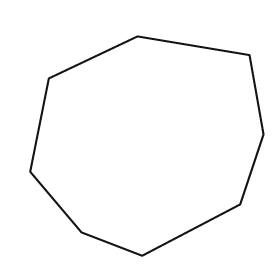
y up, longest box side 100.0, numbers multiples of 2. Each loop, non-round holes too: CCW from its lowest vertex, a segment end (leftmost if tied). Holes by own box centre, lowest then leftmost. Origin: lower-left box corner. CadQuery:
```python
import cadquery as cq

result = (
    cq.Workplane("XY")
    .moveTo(48.0, 0.0)
    .lineTo(90.0, 22.0)
    .lineTo(100.0, 52.0)
    .lineTo(94.0, 86.0)
    .lineTo(46.0, 94.0)
    .lineTo(8.0, 76.0)
    .lineTo(0.0, 36.0)
    .lineTo(22.0, 10.0)
    .close()
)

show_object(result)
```